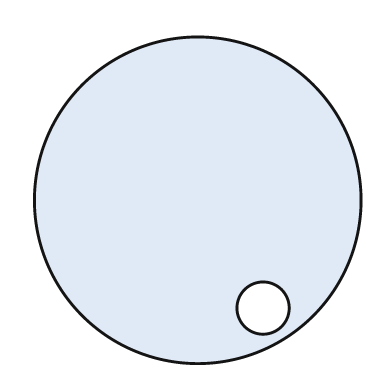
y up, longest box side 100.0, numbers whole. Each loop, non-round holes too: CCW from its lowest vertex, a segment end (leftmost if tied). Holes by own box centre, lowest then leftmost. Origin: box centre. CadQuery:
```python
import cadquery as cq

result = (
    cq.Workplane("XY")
    .moveTo(0.0, 0.0)
    .circle(50.0)
    .moveTo(20.0, -33.0)
    .circle(8.0)
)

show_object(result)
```